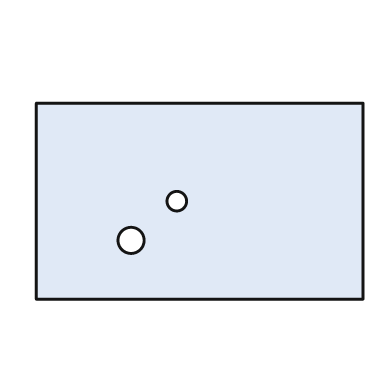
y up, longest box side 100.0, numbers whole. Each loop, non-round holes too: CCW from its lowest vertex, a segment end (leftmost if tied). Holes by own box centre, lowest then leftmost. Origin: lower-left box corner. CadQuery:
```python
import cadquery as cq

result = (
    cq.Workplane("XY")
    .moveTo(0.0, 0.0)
    .lineTo(100.0, 0.0)
    .lineTo(100.0, 60.0)
    .lineTo(0.0, 60.0)
    .close()
    .moveTo(29.0, 18.0)
    .circle(4.0)
    .moveTo(43.0, 30.0)
    .circle(3.0)
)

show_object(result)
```